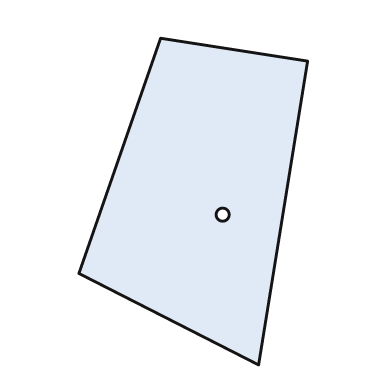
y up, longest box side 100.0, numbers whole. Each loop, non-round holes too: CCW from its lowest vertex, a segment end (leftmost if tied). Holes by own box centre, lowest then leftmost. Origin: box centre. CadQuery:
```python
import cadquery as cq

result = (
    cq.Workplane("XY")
    .moveTo(20.0, -50.0)
    .lineTo(35.0, 43.0)
    .lineTo(-10.0, 50.0)
    .lineTo(-35.0, -22.0)
    .close()
    .moveTo(9.0, -4.0)
    .circle(2.0)
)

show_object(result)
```